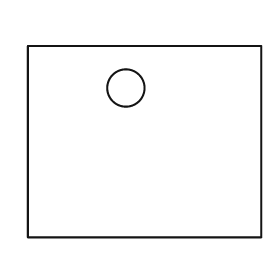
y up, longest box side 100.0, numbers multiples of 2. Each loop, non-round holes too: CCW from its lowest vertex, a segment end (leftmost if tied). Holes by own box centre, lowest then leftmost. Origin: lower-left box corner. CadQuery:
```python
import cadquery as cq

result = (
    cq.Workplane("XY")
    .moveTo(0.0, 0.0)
    .lineTo(100.0, 0.0)
    .lineTo(100.0, 82.0)
    .lineTo(0.0, 82.0)
    .close()
    .moveTo(42.0, 64.0)
    .circle(8.0)
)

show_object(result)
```